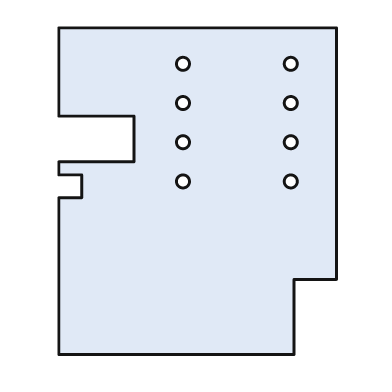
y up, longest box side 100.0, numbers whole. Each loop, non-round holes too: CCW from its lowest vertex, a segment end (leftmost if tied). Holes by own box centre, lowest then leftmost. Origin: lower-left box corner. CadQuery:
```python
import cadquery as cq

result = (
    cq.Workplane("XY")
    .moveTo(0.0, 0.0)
    .lineTo(72.0, 0.0)
    .lineTo(72.0, 23.0)
    .lineTo(85.0, 23.0)
    .lineTo(85.0, 100.0)
    .lineTo(0.0, 100.0)
    .lineTo(0.0, 73.0)
    .lineTo(23.0, 73.0)
    .lineTo(23.0, 59.0)
    .lineTo(0.0, 59.0)
    .lineTo(0.0, 55.0)
    .lineTo(7.0, 55.0)
    .lineTo(7.0, 48.0)
    .lineTo(0.0, 48.0)
    .close()
    .moveTo(38.0, 53.0)
    .circle(2.0)
    .moveTo(71.0, 53.0)
    .circle(2.0)
    .moveTo(38.0, 65.0)
    .circle(2.0)
    .moveTo(71.0, 65.0)
    .circle(2.0)
    .moveTo(38.0, 77.0)
    .circle(2.0)
    .moveTo(71.0, 77.0)
    .circle(2.0)
    .moveTo(38.0, 89.0)
    .circle(2.0)
    .moveTo(71.0, 89.0)
    .circle(2.0)
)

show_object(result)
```